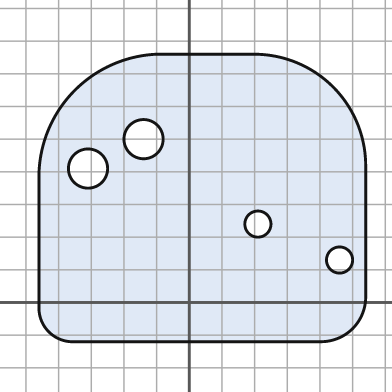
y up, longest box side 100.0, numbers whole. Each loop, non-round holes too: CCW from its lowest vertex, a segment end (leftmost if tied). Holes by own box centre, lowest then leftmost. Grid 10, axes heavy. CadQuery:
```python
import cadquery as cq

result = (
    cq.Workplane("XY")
    .moveTo(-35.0, -12.0)
    .lineTo(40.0, -12.0)
    .threePointArc((50.0, -8.0), (54.0, 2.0))
    .lineTo(54.0, 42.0)
    .threePointArc((44.0, 66.0), (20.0, 76.0))
    .lineTo(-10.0, 76.0)
    .threePointArc((-35.0, 65.0), (-46.0, 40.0))
    .lineTo(-46.0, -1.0)
    .threePointArc((-43.0, -9.0), (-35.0, -12.0))
    .close()
    .moveTo(46.0, 13.0)
    .circle(4.0)
    .moveTo(21.0, 24.0)
    .circle(4.0)
    .moveTo(-31.0, 41.0)
    .circle(6.0)
    .moveTo(-14.0, 50.0)
    .circle(6.0)
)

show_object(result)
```